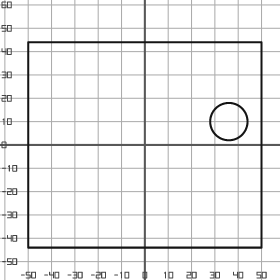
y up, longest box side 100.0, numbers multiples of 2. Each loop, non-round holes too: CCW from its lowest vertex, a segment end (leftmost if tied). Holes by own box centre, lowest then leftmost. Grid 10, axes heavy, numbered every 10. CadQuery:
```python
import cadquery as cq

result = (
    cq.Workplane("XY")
    .moveTo(-50.0, -44.0)
    .lineTo(50.0, -44.0)
    .lineTo(50.0, 44.0)
    .lineTo(-50.0, 44.0)
    .close()
    .moveTo(36.0, 10.0)
    .circle(8.0)
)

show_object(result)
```